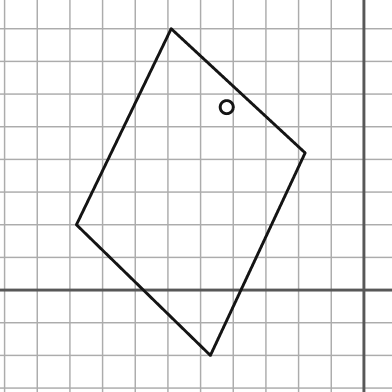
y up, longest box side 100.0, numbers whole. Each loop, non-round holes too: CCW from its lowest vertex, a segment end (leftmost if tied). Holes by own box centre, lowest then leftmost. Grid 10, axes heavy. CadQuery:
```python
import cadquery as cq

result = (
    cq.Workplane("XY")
    .moveTo(-47.0, -20.0)
    .lineTo(-18.0, 42.0)
    .lineTo(-59.0, 80.0)
    .lineTo(-88.0, 20.0)
    .close()
    .moveTo(-42.0, 56.0)
    .circle(2.0)
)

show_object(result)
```